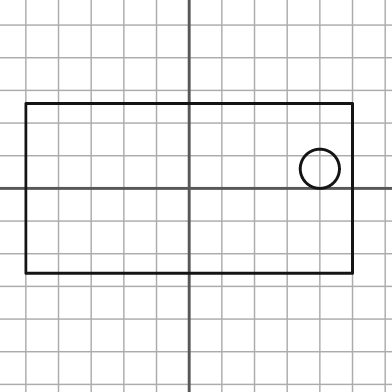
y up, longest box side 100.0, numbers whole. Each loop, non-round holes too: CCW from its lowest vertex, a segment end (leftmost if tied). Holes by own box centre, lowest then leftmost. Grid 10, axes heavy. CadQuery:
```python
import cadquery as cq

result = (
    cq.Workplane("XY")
    .moveTo(-50.0, -26.0)
    .lineTo(50.0, -26.0)
    .lineTo(50.0, 26.0)
    .lineTo(-50.0, 26.0)
    .close()
    .moveTo(40.0, 6.0)
    .circle(6.0)
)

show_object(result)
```